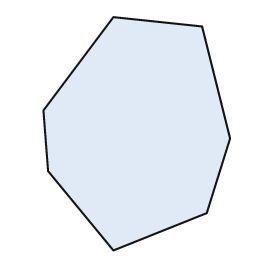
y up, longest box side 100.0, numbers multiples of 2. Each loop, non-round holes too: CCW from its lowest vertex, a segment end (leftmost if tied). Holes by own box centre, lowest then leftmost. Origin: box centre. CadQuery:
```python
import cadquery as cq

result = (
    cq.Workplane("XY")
    .moveTo(-10.0, -50.0)
    .lineTo(30.0, -34.0)
    .lineTo(40.0, -2.0)
    .lineTo(28.0, 46.0)
    .lineTo(-10.0, 50.0)
    .lineTo(-40.0, 10.0)
    .lineTo(-38.0, -16.0)
    .close()
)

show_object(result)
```